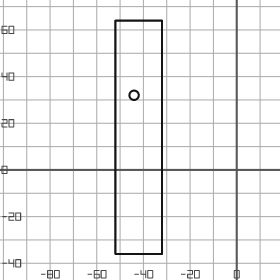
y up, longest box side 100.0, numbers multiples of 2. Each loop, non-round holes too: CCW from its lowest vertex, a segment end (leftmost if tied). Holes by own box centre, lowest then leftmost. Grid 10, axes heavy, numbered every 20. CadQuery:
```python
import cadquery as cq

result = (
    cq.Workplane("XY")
    .moveTo(-52.0, -36.0)
    .lineTo(-32.0, -36.0)
    .lineTo(-32.0, 64.0)
    .lineTo(-52.0, 64.0)
    .close()
    .moveTo(-44.0, 32.0)
    .circle(2.0)
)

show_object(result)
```